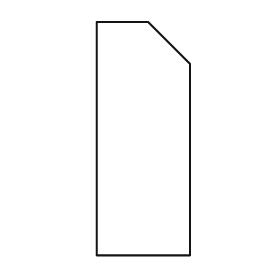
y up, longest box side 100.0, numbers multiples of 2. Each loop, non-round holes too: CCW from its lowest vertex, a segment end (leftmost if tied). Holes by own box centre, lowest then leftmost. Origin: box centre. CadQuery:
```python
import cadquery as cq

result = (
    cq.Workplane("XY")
    .moveTo(-20.0, -50.0)
    .lineTo(20.0, -50.0)
    .lineTo(20.0, 32.0)
    .lineTo(2.0, 50.0)
    .lineTo(-20.0, 50.0)
    .close()
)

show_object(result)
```